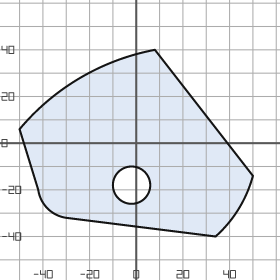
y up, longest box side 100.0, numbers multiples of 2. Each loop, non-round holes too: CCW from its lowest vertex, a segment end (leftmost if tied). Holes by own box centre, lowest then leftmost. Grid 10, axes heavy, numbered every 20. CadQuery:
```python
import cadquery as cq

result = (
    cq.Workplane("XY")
    .moveTo(34.0, -40.0)
    .threePointArc((44.0, -28.0), (50.0, -14.0))
    .lineTo(8.0, 40.0)
    .threePointArc((-24.0, 28.0), (-50.0, 6.0))
    .lineTo(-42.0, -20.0)
    .threePointArc((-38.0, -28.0), (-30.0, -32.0))
    .close()
    .moveTo(-2.0, -18.0)
    .circle(8.0)
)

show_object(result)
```